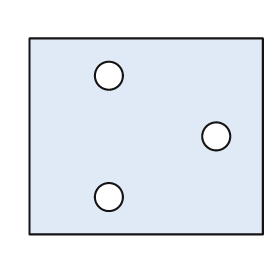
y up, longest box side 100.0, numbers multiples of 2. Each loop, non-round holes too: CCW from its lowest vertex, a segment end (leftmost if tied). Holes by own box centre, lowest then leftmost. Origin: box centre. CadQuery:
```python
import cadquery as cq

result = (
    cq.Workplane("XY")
    .moveTo(-50.0, -42.0)
    .lineTo(50.0, -42.0)
    .lineTo(50.0, 42.0)
    .lineTo(-50.0, 42.0)
    .close()
    .moveTo(-16.0, -26.0)
    .circle(6.0)
    .moveTo(30.0, 0.0)
    .circle(6.0)
    .moveTo(-16.0, 26.0)
    .circle(6.0)
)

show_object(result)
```